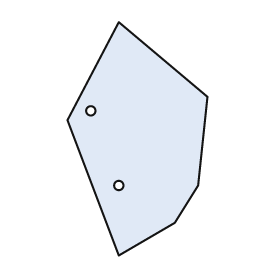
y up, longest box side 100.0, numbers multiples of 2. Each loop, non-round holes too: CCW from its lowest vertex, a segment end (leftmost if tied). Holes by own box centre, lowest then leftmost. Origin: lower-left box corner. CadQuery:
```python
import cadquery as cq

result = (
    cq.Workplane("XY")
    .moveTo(22.0, 0.0)
    .lineTo(46.0, 14.0)
    .lineTo(56.0, 30.0)
    .lineTo(60.0, 68.0)
    .lineTo(22.0, 100.0)
    .lineTo(0.0, 58.0)
    .close()
    .moveTo(22.0, 30.0)
    .circle(2.0)
    .moveTo(10.0, 62.0)
    .circle(2.0)
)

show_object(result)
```